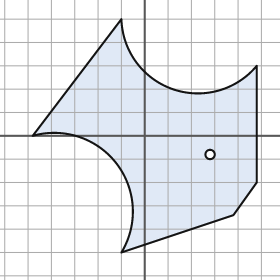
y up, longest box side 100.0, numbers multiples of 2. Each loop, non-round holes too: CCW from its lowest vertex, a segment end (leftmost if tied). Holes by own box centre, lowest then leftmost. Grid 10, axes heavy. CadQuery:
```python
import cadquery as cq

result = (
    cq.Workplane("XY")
    .moveTo(-10.0, -50.0)
    .lineTo(38.0, -34.0)
    .lineTo(48.0, -20.0)
    .lineTo(48.0, 30.0)
    .threePointArc((12.0, 20.0), (-10.0, 50.0))
    .lineTo(-48.0, 0.0)
    .threePointArc((-12.0, -12.0), (-10.0, -50.0))
    .close()
    .moveTo(28.0, -8.0)
    .circle(2.0)
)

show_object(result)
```